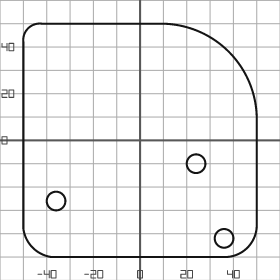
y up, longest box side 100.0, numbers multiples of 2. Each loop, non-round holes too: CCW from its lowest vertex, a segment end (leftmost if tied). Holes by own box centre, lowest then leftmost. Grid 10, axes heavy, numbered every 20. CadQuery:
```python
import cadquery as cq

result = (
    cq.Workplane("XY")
    .moveTo(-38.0, -50.0)
    .lineTo(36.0, -50.0)
    .threePointArc((46.0, -46.0), (50.0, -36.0))
    .lineTo(50.0, 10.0)
    .threePointArc((38.0, 38.0), (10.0, 50.0))
    .lineTo(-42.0, 50.0)
    .threePointArc((-48.0, 48.0), (-50.0, 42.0))
    .lineTo(-50.0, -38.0)
    .threePointArc((-46.0, -46.0), (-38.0, -50.0))
    .close()
    .moveTo(36.0, -42.0)
    .circle(4.0)
    .moveTo(-36.0, -26.0)
    .circle(4.0)
    .moveTo(24.0, -10.0)
    .circle(4.0)
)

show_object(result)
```